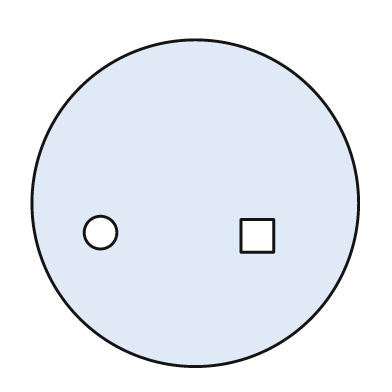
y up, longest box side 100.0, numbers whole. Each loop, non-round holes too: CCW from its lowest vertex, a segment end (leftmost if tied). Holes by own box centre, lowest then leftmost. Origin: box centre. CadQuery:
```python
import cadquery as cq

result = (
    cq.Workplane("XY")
    .moveTo(0.0, 0.0)
    .circle(50.0)
    .moveTo(14.0, -15.0)
    .lineTo(24.0, -15.0)
    .lineTo(24.0, -5.0)
    .lineTo(14.0, -5.0)
    .close()
    .moveTo(-29.0, -9.0)
    .circle(5.0)
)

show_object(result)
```